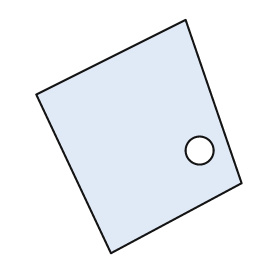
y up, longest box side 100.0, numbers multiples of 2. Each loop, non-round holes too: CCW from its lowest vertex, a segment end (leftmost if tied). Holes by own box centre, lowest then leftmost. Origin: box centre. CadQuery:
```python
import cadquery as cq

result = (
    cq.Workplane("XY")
    .moveTo(-12.0, -50.0)
    .lineTo(44.0, -20.0)
    .lineTo(20.0, 50.0)
    .lineTo(-44.0, 18.0)
    .close()
    .moveTo(26.0, -6.0)
    .circle(6.0)
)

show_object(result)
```